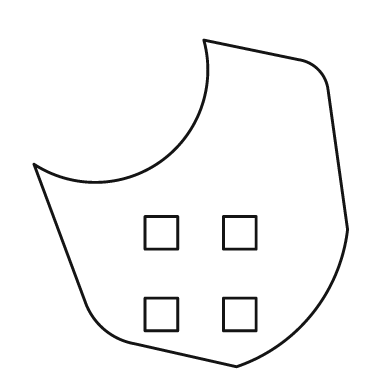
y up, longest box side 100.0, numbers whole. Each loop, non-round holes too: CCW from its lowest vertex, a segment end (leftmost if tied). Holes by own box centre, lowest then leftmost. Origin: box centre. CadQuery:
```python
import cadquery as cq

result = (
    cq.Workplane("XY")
    .moveTo(14.0, -50.0)
    .threePointArc((37.0, -34.0), (48.0, -8.0))
    .lineTo(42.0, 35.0)
    .threePointArc((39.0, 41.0), (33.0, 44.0))
    .lineTo(4.0, 50.0)
    .threePointArc((-9.0, 13.0), (-48.0, 12.0))
    .lineTo(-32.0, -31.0)
    .threePointArc((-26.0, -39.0), (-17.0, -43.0))
    .close()
    .moveTo(-14.0, -39.0)
    .lineTo(-4.0, -39.0)
    .lineTo(-4.0, -29.0)
    .lineTo(-14.0, -29.0)
    .close()
    .moveTo(10.0, -39.0)
    .lineTo(20.0, -39.0)
    .lineTo(20.0, -29.0)
    .lineTo(10.0, -29.0)
    .close()
    .moveTo(-14.0, -14.0)
    .lineTo(-4.0, -14.0)
    .lineTo(-4.0, -4.0)
    .lineTo(-14.0, -4.0)
    .close()
    .moveTo(10.0, -14.0)
    .lineTo(20.0, -14.0)
    .lineTo(20.0, -4.0)
    .lineTo(10.0, -4.0)
    .close()
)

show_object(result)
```